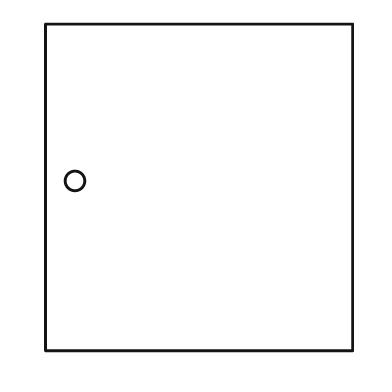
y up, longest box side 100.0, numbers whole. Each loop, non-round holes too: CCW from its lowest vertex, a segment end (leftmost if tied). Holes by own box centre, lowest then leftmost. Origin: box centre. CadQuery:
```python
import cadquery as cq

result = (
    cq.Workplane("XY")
    .moveTo(-47.0, -50.0)
    .lineTo(47.0, -50.0)
    .lineTo(47.0, 50.0)
    .lineTo(-47.0, 50.0)
    .close()
    .moveTo(-38.0, 2.0)
    .circle(3.0)
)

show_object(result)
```